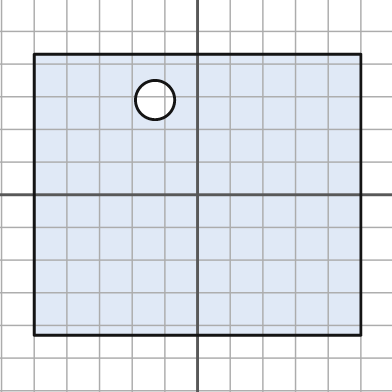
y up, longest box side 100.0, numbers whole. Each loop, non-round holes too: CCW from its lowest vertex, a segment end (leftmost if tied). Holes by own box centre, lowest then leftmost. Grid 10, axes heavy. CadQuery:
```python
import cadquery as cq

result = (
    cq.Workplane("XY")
    .moveTo(-50.0, -43.0)
    .lineTo(50.0, -43.0)
    .lineTo(50.0, 43.0)
    .lineTo(-50.0, 43.0)
    .close()
    .moveTo(-13.0, 29.0)
    .circle(6.0)
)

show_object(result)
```